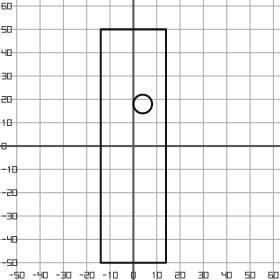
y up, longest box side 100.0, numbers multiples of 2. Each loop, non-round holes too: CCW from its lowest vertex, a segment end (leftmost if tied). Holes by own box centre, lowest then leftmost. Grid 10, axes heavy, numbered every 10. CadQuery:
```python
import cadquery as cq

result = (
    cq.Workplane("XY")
    .moveTo(-14.0, -50.0)
    .lineTo(14.0, -50.0)
    .lineTo(14.0, 50.0)
    .lineTo(-14.0, 50.0)
    .close()
    .moveTo(4.0, 18.0)
    .circle(4.0)
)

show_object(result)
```